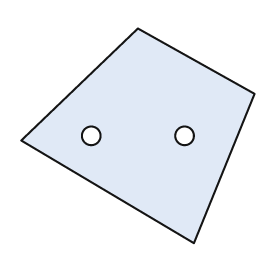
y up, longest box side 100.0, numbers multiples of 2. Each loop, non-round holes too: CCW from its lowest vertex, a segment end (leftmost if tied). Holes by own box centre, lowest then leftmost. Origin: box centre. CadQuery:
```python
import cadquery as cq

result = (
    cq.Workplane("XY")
    .moveTo(24.0, -46.0)
    .lineTo(50.0, 18.0)
    .lineTo(0.0, 46.0)
    .lineTo(-50.0, -2.0)
    .close()
    .moveTo(-20.0, 0.0)
    .circle(4.0)
    .moveTo(20.0, 0.0)
    .circle(4.0)
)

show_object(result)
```